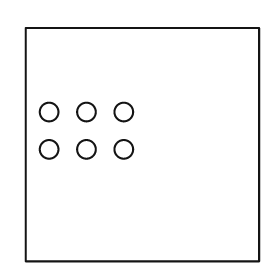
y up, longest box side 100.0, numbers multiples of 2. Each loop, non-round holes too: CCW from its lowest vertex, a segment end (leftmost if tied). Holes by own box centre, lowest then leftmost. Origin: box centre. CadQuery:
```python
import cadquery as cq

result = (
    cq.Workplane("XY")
    .moveTo(-50.0, -50.0)
    .lineTo(50.0, -50.0)
    .lineTo(50.0, 50.0)
    .lineTo(-50.0, 50.0)
    .close()
    .moveTo(-40.0, -2.0)
    .circle(4.0)
    .moveTo(-24.0, -2.0)
    .circle(4.0)
    .moveTo(-8.0, -2.0)
    .circle(4.0)
    .moveTo(-40.0, 14.0)
    .circle(4.0)
    .moveTo(-24.0, 14.0)
    .circle(4.0)
    .moveTo(-8.0, 14.0)
    .circle(4.0)
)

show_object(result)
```